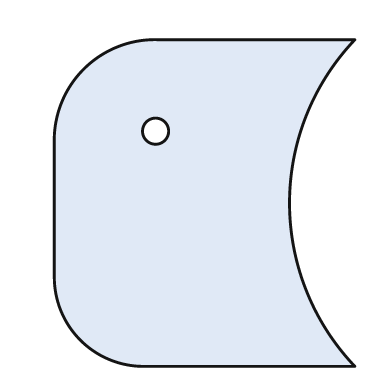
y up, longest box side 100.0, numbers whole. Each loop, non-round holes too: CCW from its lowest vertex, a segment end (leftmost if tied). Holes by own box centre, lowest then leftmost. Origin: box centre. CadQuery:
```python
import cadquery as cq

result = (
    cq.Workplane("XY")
    .moveTo(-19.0, -50.0)
    .lineTo(46.0, -50.0)
    .threePointArc((26.0, 0.0), (46.0, 50.0))
    .lineTo(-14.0, 50.0)
    .threePointArc((-37.0, 41.0), (-46.0, 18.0))
    .lineTo(-46.0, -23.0)
    .threePointArc((-38.0, -42.0), (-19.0, -50.0))
    .close()
    .moveTo(-15.0, 22.0)
    .circle(4.0)
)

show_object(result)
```